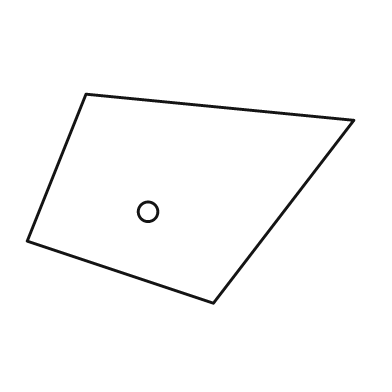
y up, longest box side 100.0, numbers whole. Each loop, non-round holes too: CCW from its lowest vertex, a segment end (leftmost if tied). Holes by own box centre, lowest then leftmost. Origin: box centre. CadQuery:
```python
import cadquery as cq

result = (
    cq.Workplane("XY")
    .moveTo(7.0, -32.0)
    .lineTo(50.0, 24.0)
    .lineTo(-32.0, 32.0)
    .lineTo(-50.0, -13.0)
    .close()
    .moveTo(-13.0, -4.0)
    .circle(3.0)
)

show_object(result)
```